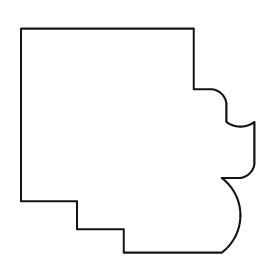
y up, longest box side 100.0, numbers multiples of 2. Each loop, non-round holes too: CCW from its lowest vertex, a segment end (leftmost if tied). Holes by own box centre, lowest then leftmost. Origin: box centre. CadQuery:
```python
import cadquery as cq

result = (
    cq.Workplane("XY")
    .moveTo(-6.0, -48.0)
    .lineTo(36.0, -48.0)
    .threePointArc((44.0, -32.0), (36.0, -16.0))
    .lineTo(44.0, -16.0)
    .threePointArc((48.0, -14.0), (50.0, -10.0))
    .lineTo(50.0, 8.0)
    .threePointArc((44.0, 6.0), (38.0, 8.0))
    .lineTo(38.0, 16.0)
    .threePointArc((36.0, 20.0), (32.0, 22.0))
    .lineTo(24.0, 22.0)
    .lineTo(24.0, 48.0)
    .lineTo(-50.0, 48.0)
    .lineTo(-50.0, -26.0)
    .lineTo(-26.0, -26.0)
    .lineTo(-26.0, -38.0)
    .lineTo(-6.0, -38.0)
    .close()
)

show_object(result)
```